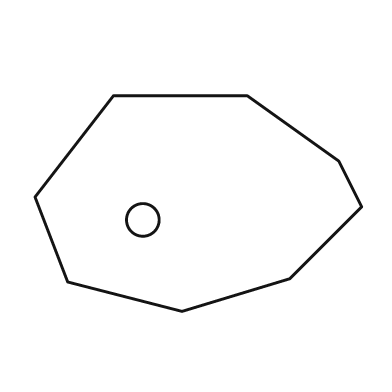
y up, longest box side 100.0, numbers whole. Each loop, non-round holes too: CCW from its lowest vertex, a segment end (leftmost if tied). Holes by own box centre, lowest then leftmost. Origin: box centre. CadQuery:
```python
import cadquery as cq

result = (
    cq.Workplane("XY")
    .moveTo(-5.0, -33.0)
    .lineTo(28.0, -23.0)
    .lineTo(50.0, -1.0)
    .lineTo(43.0, 13.0)
    .lineTo(15.0, 33.0)
    .lineTo(-26.0, 33.0)
    .lineTo(-50.0, 2.0)
    .lineTo(-40.0, -24.0)
    .close()
    .moveTo(-17.0, -5.0)
    .circle(5.0)
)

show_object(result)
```